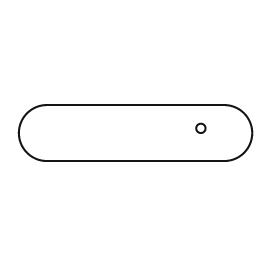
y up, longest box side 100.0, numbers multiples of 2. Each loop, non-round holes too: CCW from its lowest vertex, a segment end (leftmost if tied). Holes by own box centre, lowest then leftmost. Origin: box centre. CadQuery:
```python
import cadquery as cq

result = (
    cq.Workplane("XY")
    .moveTo(-38.0, -12.0)
    .lineTo(38.0, -12.0)
    .threePointArc((50.0, 0.0), (38.0, 12.0))
    .lineTo(-38.0, 12.0)
    .threePointArc((-50.0, 0.0), (-38.0, -12.0))
    .close()
    .moveTo(28.0, 2.0)
    .circle(2.0)
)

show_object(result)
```